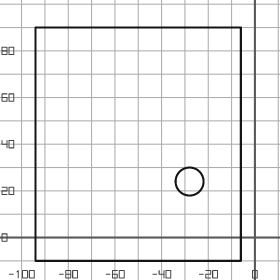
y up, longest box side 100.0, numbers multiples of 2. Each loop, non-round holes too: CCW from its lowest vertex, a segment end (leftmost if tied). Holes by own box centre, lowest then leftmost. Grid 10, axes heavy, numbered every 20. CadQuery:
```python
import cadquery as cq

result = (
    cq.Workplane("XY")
    .moveTo(-94.0, -10.0)
    .lineTo(-6.0, -10.0)
    .lineTo(-6.0, 90.0)
    .lineTo(-94.0, 90.0)
    .close()
    .moveTo(-28.0, 24.0)
    .circle(6.0)
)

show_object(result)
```